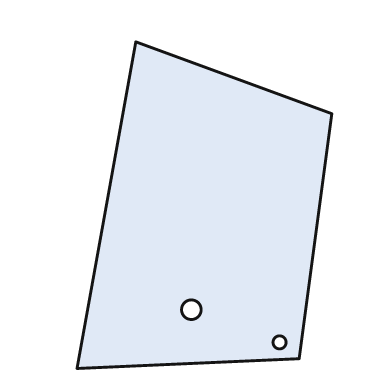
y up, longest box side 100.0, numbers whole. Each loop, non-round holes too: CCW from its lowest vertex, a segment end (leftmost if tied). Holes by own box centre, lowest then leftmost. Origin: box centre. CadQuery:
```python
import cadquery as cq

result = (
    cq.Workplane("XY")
    .moveTo(-39.0, -50.0)
    .lineTo(29.0, -47.0)
    .lineTo(39.0, 28.0)
    .lineTo(-21.0, 50.0)
    .close()
    .moveTo(23.0, -42.0)
    .circle(2.0)
    .moveTo(-4.0, -32.0)
    .circle(3.0)
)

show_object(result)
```